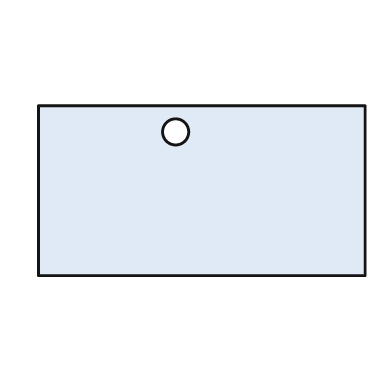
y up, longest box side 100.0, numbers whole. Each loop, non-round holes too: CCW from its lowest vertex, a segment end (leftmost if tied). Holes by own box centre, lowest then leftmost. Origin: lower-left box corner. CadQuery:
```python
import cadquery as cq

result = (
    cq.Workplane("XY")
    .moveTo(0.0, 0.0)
    .lineTo(100.0, 0.0)
    .lineTo(100.0, 52.0)
    .lineTo(0.0, 52.0)
    .close()
    .moveTo(42.0, 44.0)
    .circle(4.0)
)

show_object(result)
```